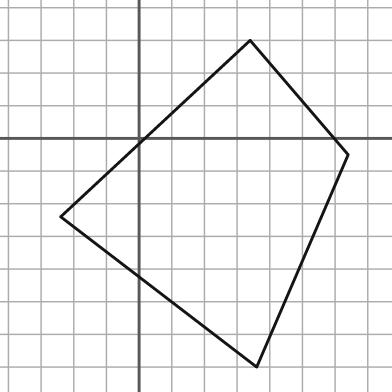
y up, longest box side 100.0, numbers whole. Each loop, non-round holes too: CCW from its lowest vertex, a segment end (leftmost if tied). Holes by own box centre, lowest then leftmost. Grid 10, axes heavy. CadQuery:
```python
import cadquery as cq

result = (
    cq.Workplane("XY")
    .moveTo(36.0, -70.0)
    .lineTo(64.0, -5.0)
    .lineTo(34.0, 30.0)
    .lineTo(-24.0, -24.0)
    .close()
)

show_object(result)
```